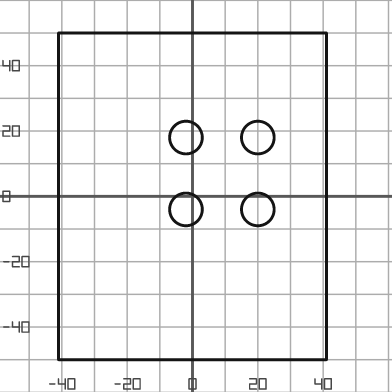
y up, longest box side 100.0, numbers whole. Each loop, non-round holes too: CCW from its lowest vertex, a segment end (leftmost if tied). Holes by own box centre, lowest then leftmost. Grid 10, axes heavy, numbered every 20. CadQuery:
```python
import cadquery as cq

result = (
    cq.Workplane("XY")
    .moveTo(-41.0, -50.0)
    .lineTo(41.0, -50.0)
    .lineTo(41.0, 50.0)
    .lineTo(-41.0, 50.0)
    .close()
    .moveTo(-2.0, -4.0)
    .circle(5.0)
    .moveTo(20.0, -4.0)
    .circle(5.0)
    .moveTo(-2.0, 18.0)
    .circle(5.0)
    .moveTo(20.0, 18.0)
    .circle(5.0)
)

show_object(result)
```